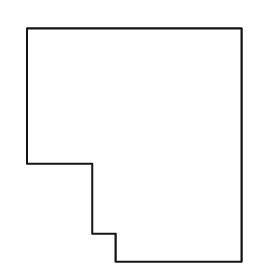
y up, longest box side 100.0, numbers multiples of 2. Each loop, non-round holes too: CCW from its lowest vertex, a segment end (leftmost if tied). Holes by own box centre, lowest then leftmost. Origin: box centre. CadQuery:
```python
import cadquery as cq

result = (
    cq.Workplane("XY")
    .moveTo(-8.0, -50.0)
    .lineTo(46.0, -50.0)
    .lineTo(46.0, 50.0)
    .lineTo(-46.0, 50.0)
    .lineTo(-46.0, -8.0)
    .lineTo(-18.0, -8.0)
    .lineTo(-18.0, -38.0)
    .lineTo(-8.0, -38.0)
    .close()
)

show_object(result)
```